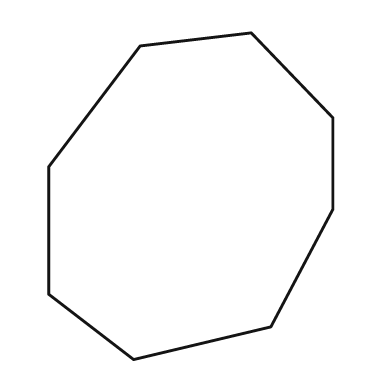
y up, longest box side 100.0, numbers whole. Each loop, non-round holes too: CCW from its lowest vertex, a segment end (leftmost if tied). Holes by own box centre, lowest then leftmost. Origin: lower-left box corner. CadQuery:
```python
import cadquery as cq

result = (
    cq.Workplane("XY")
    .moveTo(26.0, 0.0)
    .lineTo(68.0, 10.0)
    .lineTo(87.0, 46.0)
    .lineTo(87.0, 74.0)
    .lineTo(62.0, 100.0)
    .lineTo(28.0, 96.0)
    .lineTo(0.0, 59.0)
    .lineTo(0.0, 20.0)
    .close()
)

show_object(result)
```